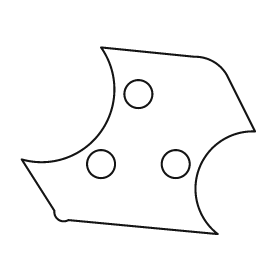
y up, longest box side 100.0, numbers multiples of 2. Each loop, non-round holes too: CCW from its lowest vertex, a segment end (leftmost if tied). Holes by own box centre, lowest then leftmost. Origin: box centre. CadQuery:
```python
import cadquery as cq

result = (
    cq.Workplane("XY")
    .moveTo(34.0, -40.0)
    .threePointArc((26.0, -12.0), (50.0, 4.0))
    .lineTo(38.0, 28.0)
    .threePointArc((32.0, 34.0), (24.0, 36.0))
    .lineTo(-16.0, 40.0)
    .threePointArc((-16.0, 4.0), (-50.0, -8.0))
    .lineTo(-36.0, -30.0)
    .threePointArc((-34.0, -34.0), (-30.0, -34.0))
    .close()
    .moveTo(-16.0, -10.0)
    .circle(6.0)
    .moveTo(16.0, -10.0)
    .circle(6.0)
    .moveTo(0.0, 20.0)
    .circle(6.0)
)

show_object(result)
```